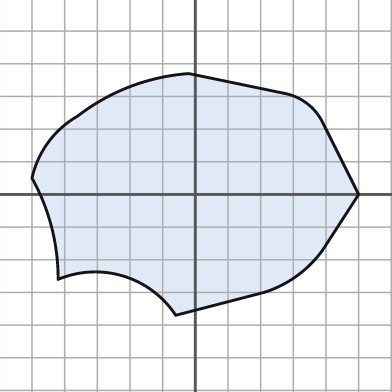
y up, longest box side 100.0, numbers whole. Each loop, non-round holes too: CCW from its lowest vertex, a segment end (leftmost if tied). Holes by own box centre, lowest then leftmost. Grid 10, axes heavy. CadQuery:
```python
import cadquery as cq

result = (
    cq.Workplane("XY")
    .moveTo(-6.0, -37.0)
    .lineTo(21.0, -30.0)
    .threePointArc((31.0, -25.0), (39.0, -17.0))
    .lineTo(50.0, 0.0)
    .lineTo(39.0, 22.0)
    .threePointArc((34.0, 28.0), (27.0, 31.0))
    .lineTo(-2.0, 37.0)
    .threePointArc((-20.0, 33.0), (-36.0, 24.0))
    .threePointArc((-45.0, 16.0), (-50.0, 5.0))
    .threePointArc((-44.0, -10.0), (-42.0, -26.0))
    .threePointArc((-22.0, -25.0), (-6.0, -37.0))
    .close()
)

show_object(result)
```